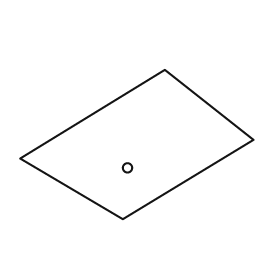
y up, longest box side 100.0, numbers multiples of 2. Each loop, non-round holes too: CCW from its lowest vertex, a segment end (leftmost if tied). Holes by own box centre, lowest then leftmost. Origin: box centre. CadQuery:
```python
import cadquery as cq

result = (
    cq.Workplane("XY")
    .moveTo(-6.0, -32.0)
    .lineTo(50.0, 2.0)
    .lineTo(12.0, 32.0)
    .lineTo(-50.0, -6.0)
    .close()
    .moveTo(-4.0, -10.0)
    .circle(2.0)
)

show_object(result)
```